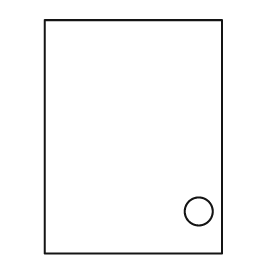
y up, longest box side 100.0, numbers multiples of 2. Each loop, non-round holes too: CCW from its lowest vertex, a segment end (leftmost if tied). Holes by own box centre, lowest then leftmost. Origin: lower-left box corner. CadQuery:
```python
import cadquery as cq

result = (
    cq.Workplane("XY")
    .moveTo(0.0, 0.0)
    .lineTo(76.0, 0.0)
    .lineTo(76.0, 100.0)
    .lineTo(0.0, 100.0)
    .close()
    .moveTo(66.0, 18.0)
    .circle(6.0)
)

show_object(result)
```